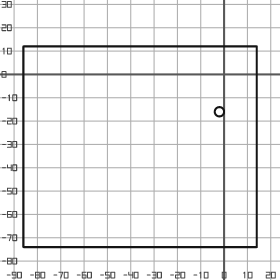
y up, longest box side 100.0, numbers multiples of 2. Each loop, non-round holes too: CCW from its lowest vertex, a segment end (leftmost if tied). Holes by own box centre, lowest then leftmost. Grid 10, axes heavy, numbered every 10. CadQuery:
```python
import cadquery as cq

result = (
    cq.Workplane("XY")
    .moveTo(-86.0, -74.0)
    .lineTo(14.0, -74.0)
    .lineTo(14.0, 12.0)
    .lineTo(-86.0, 12.0)
    .close()
    .moveTo(-2.0, -16.0)
    .circle(2.0)
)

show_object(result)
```